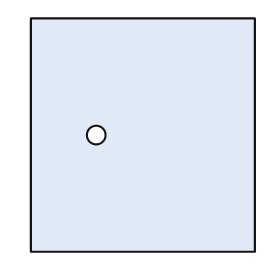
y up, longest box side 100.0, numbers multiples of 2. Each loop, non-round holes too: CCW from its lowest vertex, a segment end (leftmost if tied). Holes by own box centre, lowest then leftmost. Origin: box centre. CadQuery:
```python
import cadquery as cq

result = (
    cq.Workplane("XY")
    .moveTo(-48.0, -50.0)
    .lineTo(48.0, -50.0)
    .lineTo(48.0, 50.0)
    .lineTo(-48.0, 50.0)
    .close()
    .moveTo(-20.0, 0.0)
    .circle(4.0)
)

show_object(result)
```